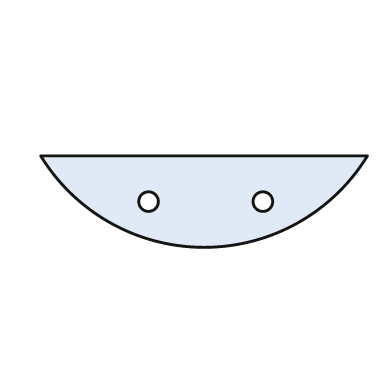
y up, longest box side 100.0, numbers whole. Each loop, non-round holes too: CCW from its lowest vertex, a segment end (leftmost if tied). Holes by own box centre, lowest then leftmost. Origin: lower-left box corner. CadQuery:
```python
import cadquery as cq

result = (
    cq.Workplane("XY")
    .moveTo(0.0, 28.0)
    .threePointArc((50.0, 0.0), (100.0, 28.0))
    .close()
    .moveTo(33.0, 14.0)
    .circle(3.0)
    .moveTo(68.0, 14.0)
    .circle(3.0)
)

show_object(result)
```